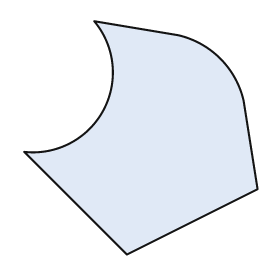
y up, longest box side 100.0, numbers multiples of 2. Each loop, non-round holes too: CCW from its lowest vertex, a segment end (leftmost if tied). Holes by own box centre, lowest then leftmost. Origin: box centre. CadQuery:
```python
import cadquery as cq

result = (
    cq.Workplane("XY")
    .moveTo(-6.0, -50.0)
    .lineTo(50.0, -22.0)
    .lineTo(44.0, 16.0)
    .threePointArc((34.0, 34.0), (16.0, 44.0))
    .lineTo(-20.0, 50.0)
    .threePointArc((-16.0, 12.0), (-50.0, -6.0))
    .close()
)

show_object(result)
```